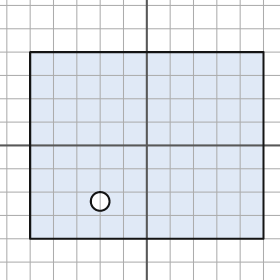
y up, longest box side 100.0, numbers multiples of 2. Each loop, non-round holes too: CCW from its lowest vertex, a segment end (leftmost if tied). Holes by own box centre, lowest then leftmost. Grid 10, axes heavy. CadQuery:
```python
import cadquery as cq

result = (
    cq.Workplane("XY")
    .moveTo(-50.0, -40.0)
    .lineTo(50.0, -40.0)
    .lineTo(50.0, 40.0)
    .lineTo(-50.0, 40.0)
    .close()
    .moveTo(-20.0, -24.0)
    .circle(4.0)
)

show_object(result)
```